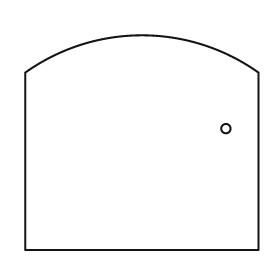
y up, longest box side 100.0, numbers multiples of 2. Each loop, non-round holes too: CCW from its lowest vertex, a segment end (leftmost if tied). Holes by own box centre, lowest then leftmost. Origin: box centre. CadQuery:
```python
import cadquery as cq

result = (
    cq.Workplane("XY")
    .moveTo(-50.0, -46.0)
    .lineTo(50.0, -46.0)
    .lineTo(50.0, 30.0)
    .threePointArc((0.0, 46.0), (-50.0, 30.0))
    .close()
    .moveTo(36.0, 6.0)
    .circle(2.0)
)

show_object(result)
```